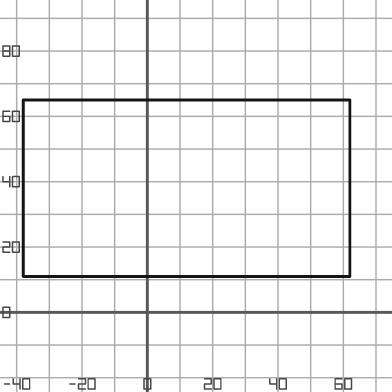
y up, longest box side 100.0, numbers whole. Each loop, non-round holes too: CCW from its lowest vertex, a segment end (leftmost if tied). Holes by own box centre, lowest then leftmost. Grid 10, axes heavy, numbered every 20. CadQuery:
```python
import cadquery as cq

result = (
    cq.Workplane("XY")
    .moveTo(-38.0, 11.0)
    .lineTo(62.0, 11.0)
    .lineTo(62.0, 65.0)
    .lineTo(-38.0, 65.0)
    .close()
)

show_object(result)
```